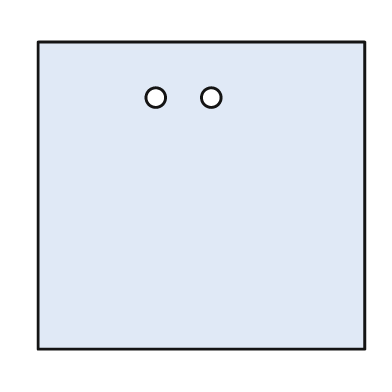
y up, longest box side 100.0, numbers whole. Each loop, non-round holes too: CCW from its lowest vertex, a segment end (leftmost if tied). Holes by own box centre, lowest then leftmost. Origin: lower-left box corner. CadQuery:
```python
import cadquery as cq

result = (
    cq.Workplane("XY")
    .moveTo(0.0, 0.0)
    .lineTo(100.0, 0.0)
    .lineTo(100.0, 94.0)
    .lineTo(0.0, 94.0)
    .close()
    .moveTo(36.0, 77.0)
    .circle(3.0)
    .moveTo(53.0, 77.0)
    .circle(3.0)
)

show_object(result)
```